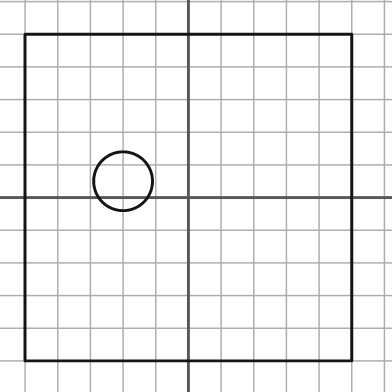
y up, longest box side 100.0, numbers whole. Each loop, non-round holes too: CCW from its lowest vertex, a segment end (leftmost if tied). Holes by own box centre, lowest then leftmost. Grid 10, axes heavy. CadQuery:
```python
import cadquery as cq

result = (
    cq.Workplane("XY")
    .moveTo(-50.0, -50.0)
    .lineTo(50.0, -50.0)
    .lineTo(50.0, 50.0)
    .lineTo(-50.0, 50.0)
    .close()
    .moveTo(-20.0, 5.0)
    .circle(9.0)
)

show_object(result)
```